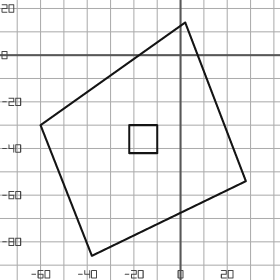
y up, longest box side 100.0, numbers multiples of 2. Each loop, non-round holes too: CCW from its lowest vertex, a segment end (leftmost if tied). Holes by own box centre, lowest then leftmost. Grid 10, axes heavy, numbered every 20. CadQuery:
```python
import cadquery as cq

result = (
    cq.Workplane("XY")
    .moveTo(-38.0, -86.0)
    .lineTo(28.0, -54.0)
    .lineTo(2.0, 14.0)
    .lineTo(-60.0, -30.0)
    .close()
    .moveTo(-22.0, -42.0)
    .lineTo(-10.0, -42.0)
    .lineTo(-10.0, -30.0)
    .lineTo(-22.0, -30.0)
    .close()
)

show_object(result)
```